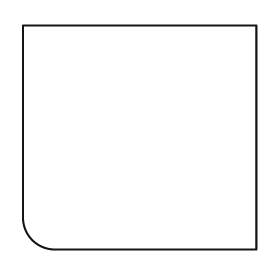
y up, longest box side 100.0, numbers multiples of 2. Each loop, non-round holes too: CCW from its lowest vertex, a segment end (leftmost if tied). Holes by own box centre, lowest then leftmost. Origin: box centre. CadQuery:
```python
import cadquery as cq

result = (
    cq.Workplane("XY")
    .moveTo(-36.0, -48.0)
    .lineTo(50.0, -48.0)
    .lineTo(50.0, 48.0)
    .lineTo(-50.0, 48.0)
    .lineTo(-50.0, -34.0)
    .threePointArc((-46.0, -44.0), (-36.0, -48.0))
    .close()
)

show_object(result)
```